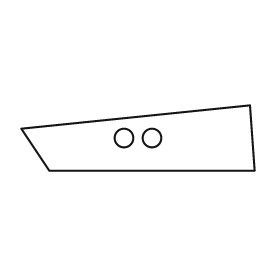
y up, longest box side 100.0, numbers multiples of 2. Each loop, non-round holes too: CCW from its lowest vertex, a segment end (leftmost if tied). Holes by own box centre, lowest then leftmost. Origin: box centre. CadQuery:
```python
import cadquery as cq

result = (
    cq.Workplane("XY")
    .moveTo(-38.0, -14.0)
    .lineTo(50.0, -14.0)
    .lineTo(48.0, 14.0)
    .lineTo(-50.0, 4.0)
    .close()
    .moveTo(-6.0, 0.0)
    .circle(4.0)
    .moveTo(6.0, 0.0)
    .circle(4.0)
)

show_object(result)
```